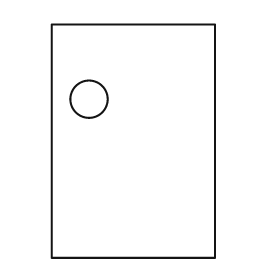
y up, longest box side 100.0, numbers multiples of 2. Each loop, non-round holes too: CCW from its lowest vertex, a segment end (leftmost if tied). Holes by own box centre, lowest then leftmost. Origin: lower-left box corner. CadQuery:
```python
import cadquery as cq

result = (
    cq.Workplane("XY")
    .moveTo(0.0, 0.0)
    .lineTo(70.0, 0.0)
    .lineTo(70.0, 100.0)
    .lineTo(0.0, 100.0)
    .close()
    .moveTo(16.0, 68.0)
    .circle(8.0)
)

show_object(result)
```